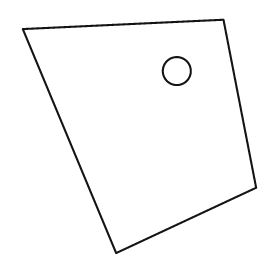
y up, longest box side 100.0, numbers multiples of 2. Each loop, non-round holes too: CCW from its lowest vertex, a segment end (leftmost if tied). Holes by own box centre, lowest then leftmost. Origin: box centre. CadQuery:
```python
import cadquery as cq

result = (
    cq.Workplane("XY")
    .moveTo(-10.0, -50.0)
    .lineTo(50.0, -22.0)
    .lineTo(36.0, 50.0)
    .lineTo(-50.0, 46.0)
    .close()
    .moveTo(16.0, 28.0)
    .circle(6.0)
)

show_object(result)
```